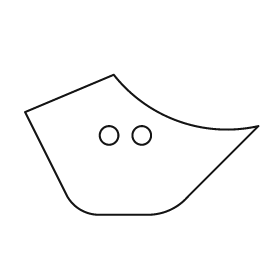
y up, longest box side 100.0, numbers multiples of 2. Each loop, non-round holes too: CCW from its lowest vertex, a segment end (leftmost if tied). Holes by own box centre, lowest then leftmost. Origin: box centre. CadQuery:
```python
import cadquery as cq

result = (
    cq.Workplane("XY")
    .moveTo(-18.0, -30.0)
    .lineTo(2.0, -30.0)
    .threePointArc((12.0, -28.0), (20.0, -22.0))
    .lineTo(50.0, 8.0)
    .threePointArc((16.0, 10.0), (-12.0, 30.0))
    .lineTo(-50.0, 14.0)
    .lineTo(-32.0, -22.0)
    .threePointArc((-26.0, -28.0), (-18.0, -30.0))
    .close()
    .moveTo(-14.0, 4.0)
    .circle(4.0)
    .moveTo(0.0, 4.0)
    .circle(4.0)
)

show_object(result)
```